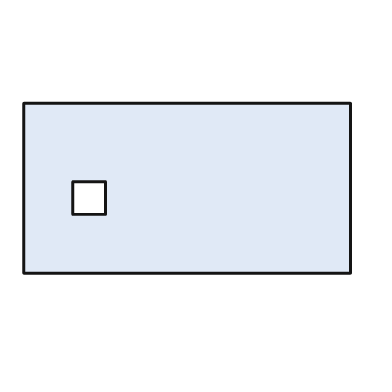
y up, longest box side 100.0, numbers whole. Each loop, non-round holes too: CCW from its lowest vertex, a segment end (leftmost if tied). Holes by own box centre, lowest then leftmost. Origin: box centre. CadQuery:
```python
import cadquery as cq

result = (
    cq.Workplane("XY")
    .moveTo(-50.0, -26.0)
    .lineTo(50.0, -26.0)
    .lineTo(50.0, 26.0)
    .lineTo(-50.0, 26.0)
    .close()
    .moveTo(-35.0, -8.0)
    .lineTo(-25.0, -8.0)
    .lineTo(-25.0, 2.0)
    .lineTo(-35.0, 2.0)
    .close()
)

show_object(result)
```